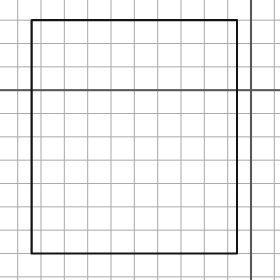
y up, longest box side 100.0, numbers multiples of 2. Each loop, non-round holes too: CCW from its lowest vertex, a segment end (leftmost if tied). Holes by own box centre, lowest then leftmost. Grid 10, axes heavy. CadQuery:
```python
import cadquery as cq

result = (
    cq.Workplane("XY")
    .moveTo(-94.0, -70.0)
    .lineTo(-6.0, -70.0)
    .lineTo(-6.0, 30.0)
    .lineTo(-94.0, 30.0)
    .close()
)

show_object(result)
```